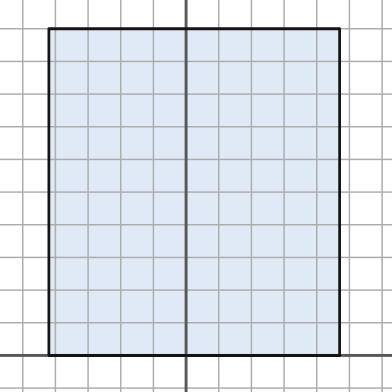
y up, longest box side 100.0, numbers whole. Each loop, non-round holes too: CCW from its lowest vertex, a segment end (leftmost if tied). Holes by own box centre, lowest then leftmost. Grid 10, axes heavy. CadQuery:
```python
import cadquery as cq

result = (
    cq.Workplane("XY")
    .moveTo(-42.0, 0.0)
    .lineTo(47.0, 0.0)
    .lineTo(47.0, 100.0)
    .lineTo(-42.0, 100.0)
    .close()
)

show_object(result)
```